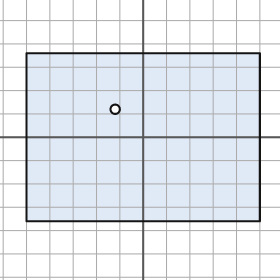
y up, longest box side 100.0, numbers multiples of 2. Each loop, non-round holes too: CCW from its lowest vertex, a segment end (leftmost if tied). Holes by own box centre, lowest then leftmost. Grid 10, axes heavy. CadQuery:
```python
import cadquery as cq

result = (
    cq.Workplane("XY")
    .moveTo(-50.0, -36.0)
    .lineTo(50.0, -36.0)
    .lineTo(50.0, 36.0)
    .lineTo(-50.0, 36.0)
    .close()
    .moveTo(-12.0, 12.0)
    .circle(2.0)
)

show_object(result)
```